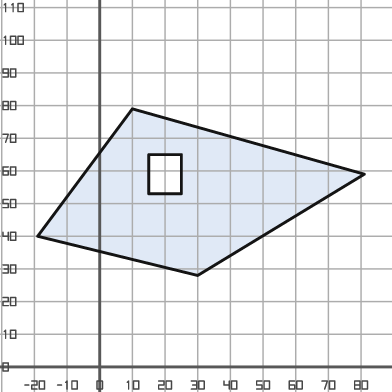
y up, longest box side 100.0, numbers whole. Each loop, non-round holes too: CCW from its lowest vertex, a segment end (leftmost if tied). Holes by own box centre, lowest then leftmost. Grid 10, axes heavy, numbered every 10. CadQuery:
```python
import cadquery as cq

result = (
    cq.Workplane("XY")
    .moveTo(30.0, 28.0)
    .lineTo(81.0, 59.0)
    .lineTo(10.0, 79.0)
    .lineTo(-19.0, 40.0)
    .close()
    .moveTo(15.0, 53.0)
    .lineTo(25.0, 53.0)
    .lineTo(25.0, 65.0)
    .lineTo(15.0, 65.0)
    .close()
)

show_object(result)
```